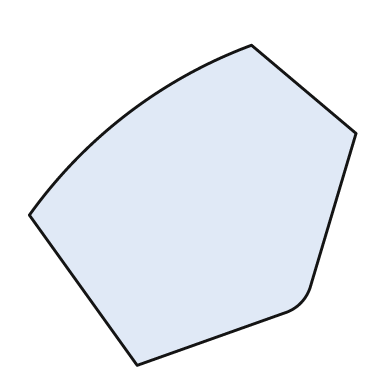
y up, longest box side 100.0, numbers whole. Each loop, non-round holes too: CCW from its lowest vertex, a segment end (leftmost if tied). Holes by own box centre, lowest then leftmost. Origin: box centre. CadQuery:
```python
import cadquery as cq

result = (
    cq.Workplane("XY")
    .moveTo(-17.0, -49.0)
    .lineTo(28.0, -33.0)
    .threePointArc((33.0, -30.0), (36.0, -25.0))
    .lineTo(50.0, 22.0)
    .lineTo(18.0, 49.0)
    .threePointArc((-20.0, 28.0), (-50.0, -3.0))
    .close()
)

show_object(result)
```